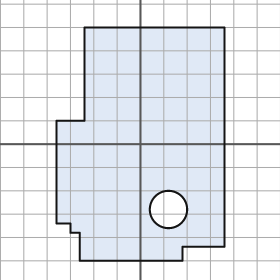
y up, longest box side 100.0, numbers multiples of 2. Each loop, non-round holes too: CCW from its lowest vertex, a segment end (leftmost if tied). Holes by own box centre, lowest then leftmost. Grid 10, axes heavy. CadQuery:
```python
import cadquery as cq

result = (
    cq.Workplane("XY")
    .moveTo(-26.0, -50.0)
    .lineTo(18.0, -50.0)
    .lineTo(18.0, -44.0)
    .lineTo(36.0, -44.0)
    .lineTo(36.0, 50.0)
    .lineTo(-24.0, 50.0)
    .lineTo(-24.0, 10.0)
    .lineTo(-36.0, 10.0)
    .lineTo(-36.0, -34.0)
    .lineTo(-30.0, -34.0)
    .lineTo(-30.0, -38.0)
    .lineTo(-26.0, -38.0)
    .close()
    .moveTo(12.0, -28.0)
    .circle(8.0)
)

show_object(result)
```